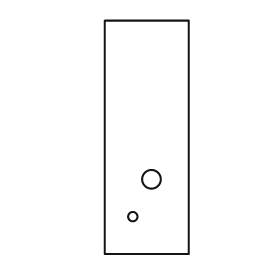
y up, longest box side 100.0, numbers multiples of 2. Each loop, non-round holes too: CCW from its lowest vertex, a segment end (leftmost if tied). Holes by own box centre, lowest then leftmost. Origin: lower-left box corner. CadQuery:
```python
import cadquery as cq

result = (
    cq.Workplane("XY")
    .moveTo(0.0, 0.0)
    .lineTo(36.0, 0.0)
    .lineTo(36.0, 100.0)
    .lineTo(0.0, 100.0)
    .close()
    .moveTo(12.0, 16.0)
    .circle(2.0)
    .moveTo(20.0, 32.0)
    .circle(4.0)
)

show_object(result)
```